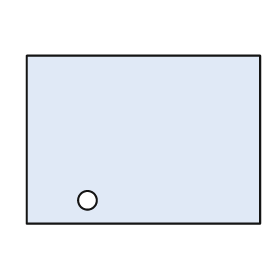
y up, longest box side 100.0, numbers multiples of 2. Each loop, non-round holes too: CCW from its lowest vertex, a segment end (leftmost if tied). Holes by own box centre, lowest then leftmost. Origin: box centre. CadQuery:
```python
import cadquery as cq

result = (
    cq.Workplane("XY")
    .moveTo(-50.0, -36.0)
    .lineTo(50.0, -36.0)
    .lineTo(50.0, 36.0)
    .lineTo(-50.0, 36.0)
    .close()
    .moveTo(-24.0, -26.0)
    .circle(4.0)
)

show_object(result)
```